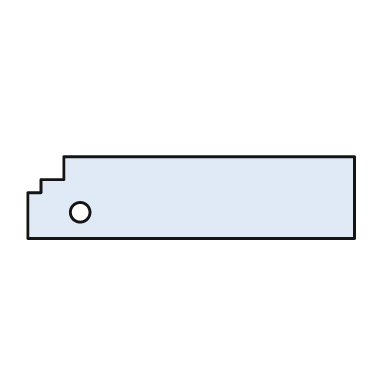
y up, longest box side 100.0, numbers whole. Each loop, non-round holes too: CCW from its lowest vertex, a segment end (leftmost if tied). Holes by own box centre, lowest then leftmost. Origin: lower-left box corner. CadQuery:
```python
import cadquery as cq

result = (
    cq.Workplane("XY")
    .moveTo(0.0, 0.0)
    .lineTo(100.0, 0.0)
    .lineTo(100.0, 25.0)
    .lineTo(11.0, 25.0)
    .lineTo(11.0, 18.0)
    .lineTo(4.0, 18.0)
    .lineTo(4.0, 14.0)
    .lineTo(0.0, 14.0)
    .close()
    .moveTo(16.0, 8.0)
    .circle(3.0)
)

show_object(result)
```